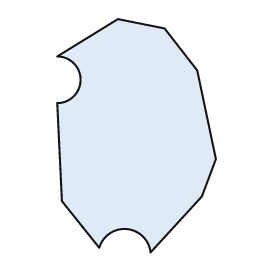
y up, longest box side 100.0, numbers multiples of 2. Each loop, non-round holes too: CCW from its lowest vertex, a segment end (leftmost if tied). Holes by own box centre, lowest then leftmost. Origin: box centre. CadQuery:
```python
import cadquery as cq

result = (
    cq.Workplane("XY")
    .moveTo(6.0, -50.0)
    .lineTo(28.0, -26.0)
    .lineTo(34.0, -10.0)
    .lineTo(26.0, 28.0)
    .lineTo(12.0, 46.0)
    .lineTo(-8.0, 50.0)
    .lineTo(-34.0, 34.0)
    .threePointArc((-24.0, 24.0), (-34.0, 14.0))
    .lineTo(-32.0, -28.0)
    .lineTo(-16.0, -48.0)
    .threePointArc((-4.0, -40.0), (6.0, -50.0))
    .close()
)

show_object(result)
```